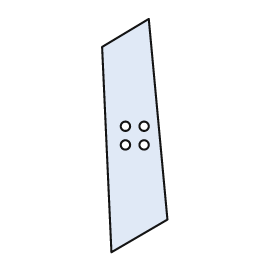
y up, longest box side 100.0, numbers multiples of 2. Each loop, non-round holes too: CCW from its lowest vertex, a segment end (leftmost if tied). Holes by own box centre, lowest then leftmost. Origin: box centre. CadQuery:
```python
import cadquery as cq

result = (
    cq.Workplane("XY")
    .moveTo(-10.0, -50.0)
    .lineTo(14.0, -36.0)
    .lineTo(6.0, 50.0)
    .lineTo(-14.0, 38.0)
    .close()
    .moveTo(-4.0, -4.0)
    .circle(2.0)
    .moveTo(4.0, -4.0)
    .circle(2.0)
    .moveTo(-4.0, 4.0)
    .circle(2.0)
    .moveTo(4.0, 4.0)
    .circle(2.0)
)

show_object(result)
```